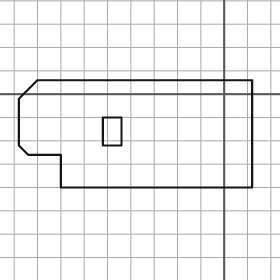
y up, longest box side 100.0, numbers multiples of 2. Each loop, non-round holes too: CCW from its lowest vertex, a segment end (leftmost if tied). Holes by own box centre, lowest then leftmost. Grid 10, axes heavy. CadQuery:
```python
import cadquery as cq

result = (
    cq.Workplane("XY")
    .moveTo(-70.0, -40.0)
    .lineTo(12.0, -40.0)
    .lineTo(12.0, 6.0)
    .lineTo(-80.0, 6.0)
    .lineTo(-88.0, -2.0)
    .lineTo(-88.0, -22.0)
    .lineTo(-84.0, -26.0)
    .lineTo(-70.0, -26.0)
    .close()
    .moveTo(-52.0, -22.0)
    .lineTo(-44.0, -22.0)
    .lineTo(-44.0, -10.0)
    .lineTo(-52.0, -10.0)
    .close()
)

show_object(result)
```